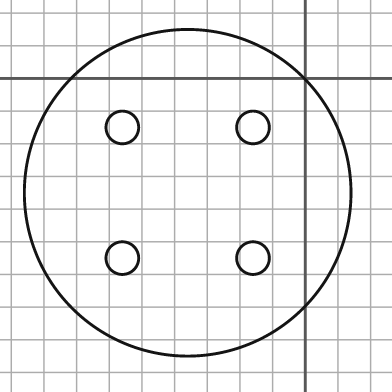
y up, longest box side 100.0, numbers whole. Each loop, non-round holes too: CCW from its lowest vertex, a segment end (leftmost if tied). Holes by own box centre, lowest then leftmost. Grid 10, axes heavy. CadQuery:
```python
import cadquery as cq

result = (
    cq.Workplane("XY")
    .moveTo(-36.0, -35.0)
    .circle(50.0)
    .moveTo(-56.0, -55.0)
    .circle(5.0)
    .moveTo(-16.0, -55.0)
    .circle(5.0)
    .moveTo(-56.0, -15.0)
    .circle(5.0)
    .moveTo(-16.0, -15.0)
    .circle(5.0)
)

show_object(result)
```